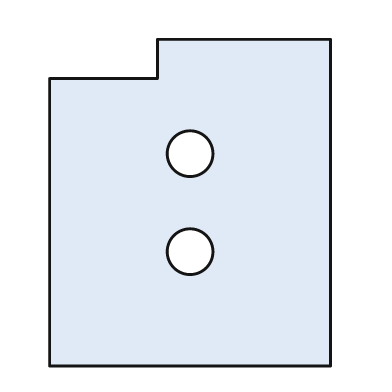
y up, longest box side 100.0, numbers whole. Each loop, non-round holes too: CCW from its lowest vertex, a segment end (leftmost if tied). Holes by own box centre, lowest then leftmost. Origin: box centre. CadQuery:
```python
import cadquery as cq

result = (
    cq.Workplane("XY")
    .moveTo(-43.0, -50.0)
    .lineTo(43.0, -50.0)
    .lineTo(43.0, 50.0)
    .lineTo(-10.0, 50.0)
    .lineTo(-10.0, 38.0)
    .lineTo(-43.0, 38.0)
    .close()
    .moveTo(0.0, -15.0)
    .circle(7.0)
    .moveTo(0.0, 15.0)
    .circle(7.0)
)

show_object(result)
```